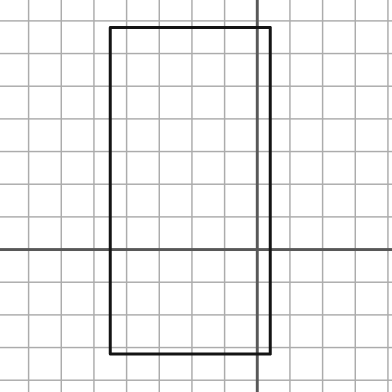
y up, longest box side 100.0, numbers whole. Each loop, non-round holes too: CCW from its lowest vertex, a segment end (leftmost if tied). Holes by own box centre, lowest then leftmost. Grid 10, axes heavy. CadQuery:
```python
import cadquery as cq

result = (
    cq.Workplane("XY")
    .moveTo(-45.0, -32.0)
    .lineTo(4.0, -32.0)
    .lineTo(4.0, 68.0)
    .lineTo(-45.0, 68.0)
    .close()
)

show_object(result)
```